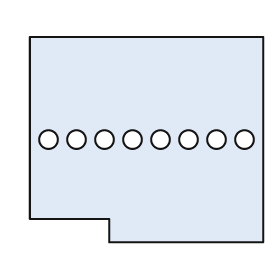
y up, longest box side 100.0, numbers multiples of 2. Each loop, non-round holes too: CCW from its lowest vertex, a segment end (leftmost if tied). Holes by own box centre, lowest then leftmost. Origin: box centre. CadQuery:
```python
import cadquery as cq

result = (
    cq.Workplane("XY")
    .moveTo(-16.0, -44.0)
    .lineTo(50.0, -44.0)
    .lineTo(50.0, 44.0)
    .lineTo(-50.0, 44.0)
    .lineTo(-50.0, -34.0)
    .lineTo(-16.0, -34.0)
    .close()
    .moveTo(-42.0, 0.0)
    .circle(4.0)
    .moveTo(-30.0, 0.0)
    .circle(4.0)
    .moveTo(-18.0, 0.0)
    .circle(4.0)
    .moveTo(-6.0, 0.0)
    .circle(4.0)
    .moveTo(6.0, 0.0)
    .circle(4.0)
    .moveTo(18.0, 0.0)
    .circle(4.0)
    .moveTo(30.0, 0.0)
    .circle(4.0)
    .moveTo(42.0, 0.0)
    .circle(4.0)
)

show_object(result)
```